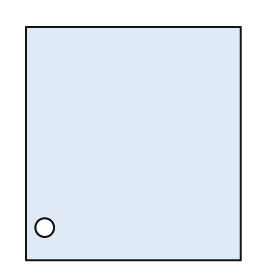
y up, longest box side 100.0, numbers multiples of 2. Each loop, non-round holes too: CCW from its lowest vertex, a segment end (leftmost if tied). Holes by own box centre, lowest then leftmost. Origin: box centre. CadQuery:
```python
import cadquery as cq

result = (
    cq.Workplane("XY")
    .moveTo(-46.0, -50.0)
    .lineTo(46.0, -50.0)
    .lineTo(46.0, 50.0)
    .lineTo(-46.0, 50.0)
    .close()
    .moveTo(-38.0, -36.0)
    .circle(4.0)
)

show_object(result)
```